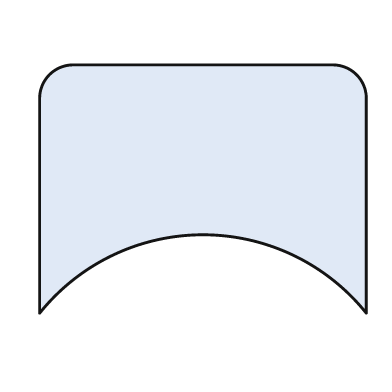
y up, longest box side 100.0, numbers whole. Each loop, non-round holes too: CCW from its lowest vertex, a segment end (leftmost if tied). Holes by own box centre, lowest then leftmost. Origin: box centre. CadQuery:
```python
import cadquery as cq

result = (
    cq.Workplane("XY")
    .moveTo(-50.0, -38.0)
    .threePointArc((0.0, -14.0), (50.0, -38.0))
    .lineTo(50.0, 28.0)
    .threePointArc((47.0, 35.0), (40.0, 38.0))
    .lineTo(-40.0, 38.0)
    .threePointArc((-47.0, 35.0), (-50.0, 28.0))
    .close()
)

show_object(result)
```